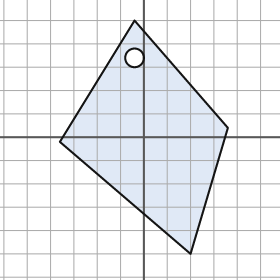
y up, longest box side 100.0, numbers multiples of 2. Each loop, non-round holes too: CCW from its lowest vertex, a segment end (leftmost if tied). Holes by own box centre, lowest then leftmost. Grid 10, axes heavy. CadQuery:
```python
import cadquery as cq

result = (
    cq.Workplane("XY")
    .moveTo(20.0, -50.0)
    .lineTo(36.0, 4.0)
    .lineTo(-4.0, 50.0)
    .lineTo(-36.0, -2.0)
    .close()
    .moveTo(-4.0, 34.0)
    .circle(4.0)
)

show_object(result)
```